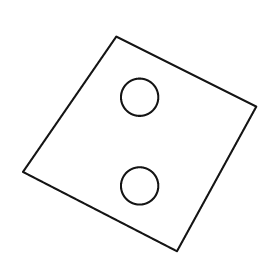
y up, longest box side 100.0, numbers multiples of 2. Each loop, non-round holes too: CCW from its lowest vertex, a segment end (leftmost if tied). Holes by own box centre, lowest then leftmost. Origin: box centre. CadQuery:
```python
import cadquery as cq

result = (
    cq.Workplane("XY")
    .moveTo(16.0, -46.0)
    .lineTo(50.0, 16.0)
    .lineTo(-10.0, 46.0)
    .lineTo(-50.0, -12.0)
    .close()
    .moveTo(0.0, -18.0)
    .circle(8.0)
    .moveTo(0.0, 20.0)
    .circle(8.0)
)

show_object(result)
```